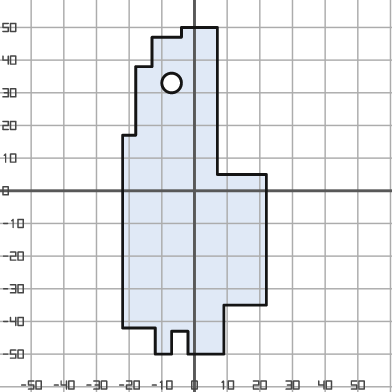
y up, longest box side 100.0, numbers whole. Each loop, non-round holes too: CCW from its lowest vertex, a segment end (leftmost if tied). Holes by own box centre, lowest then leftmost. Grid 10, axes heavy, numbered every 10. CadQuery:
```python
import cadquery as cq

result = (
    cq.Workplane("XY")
    .moveTo(-12.0, -50.0)
    .lineTo(-7.0, -50.0)
    .lineTo(-7.0, -43.0)
    .lineTo(-2.0, -43.0)
    .lineTo(-2.0, -50.0)
    .lineTo(9.0, -50.0)
    .lineTo(9.0, -35.0)
    .lineTo(22.0, -35.0)
    .lineTo(22.0, 5.0)
    .lineTo(7.0, 5.0)
    .lineTo(7.0, 50.0)
    .lineTo(-4.0, 50.0)
    .lineTo(-4.0, 47.0)
    .lineTo(-13.0, 47.0)
    .lineTo(-13.0, 38.0)
    .lineTo(-18.0, 38.0)
    .lineTo(-18.0, 17.0)
    .lineTo(-22.0, 17.0)
    .lineTo(-22.0, -42.0)
    .lineTo(-12.0, -42.0)
    .close()
    .moveTo(-7.0, 33.0)
    .circle(3.0)
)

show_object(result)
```